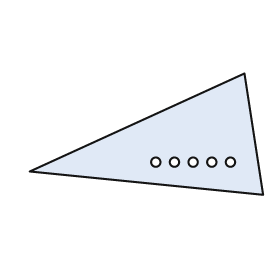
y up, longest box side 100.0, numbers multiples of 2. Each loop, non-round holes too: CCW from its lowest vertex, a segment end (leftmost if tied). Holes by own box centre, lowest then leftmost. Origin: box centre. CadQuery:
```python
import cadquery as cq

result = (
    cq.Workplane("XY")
    .moveTo(50.0, -26.0)
    .lineTo(42.0, 26.0)
    .lineTo(-50.0, -16.0)
    .close()
    .moveTo(4.0, -12.0)
    .circle(2.0)
    .moveTo(12.0, -12.0)
    .circle(2.0)
    .moveTo(20.0, -12.0)
    .circle(2.0)
    .moveTo(28.0, -12.0)
    .circle(2.0)
    .moveTo(36.0, -12.0)
    .circle(2.0)
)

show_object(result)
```